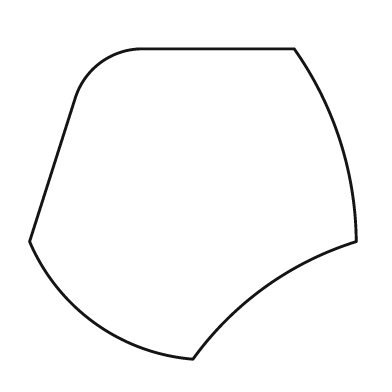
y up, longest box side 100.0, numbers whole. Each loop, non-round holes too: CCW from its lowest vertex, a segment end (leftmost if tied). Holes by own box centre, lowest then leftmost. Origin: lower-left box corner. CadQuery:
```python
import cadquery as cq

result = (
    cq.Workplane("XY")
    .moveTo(50.0, 0.0)
    .threePointArc((72.0, 22.0), (100.0, 36.0))
    .threePointArc((95.0, 67.0), (81.0, 95.0))
    .lineTo(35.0, 95.0)
    .threePointArc((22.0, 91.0), (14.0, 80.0))
    .lineTo(0.0, 36.0)
    .threePointArc((20.0, 11.0), (50.0, 0.0))
    .close()
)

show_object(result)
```